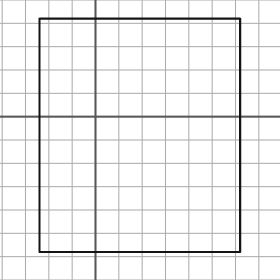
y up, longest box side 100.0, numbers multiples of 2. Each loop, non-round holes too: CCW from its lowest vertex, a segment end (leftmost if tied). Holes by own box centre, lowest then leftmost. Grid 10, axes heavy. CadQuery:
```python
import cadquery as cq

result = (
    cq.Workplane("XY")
    .moveTo(-24.0, -58.0)
    .lineTo(62.0, -58.0)
    .lineTo(62.0, 42.0)
    .lineTo(-24.0, 42.0)
    .close()
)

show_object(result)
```